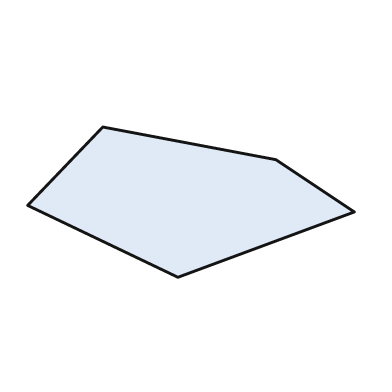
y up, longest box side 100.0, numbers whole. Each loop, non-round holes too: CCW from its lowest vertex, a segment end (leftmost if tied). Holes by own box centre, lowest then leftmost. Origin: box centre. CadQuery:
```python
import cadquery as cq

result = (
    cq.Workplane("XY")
    .moveTo(-4.0, -23.0)
    .lineTo(50.0, -3.0)
    .lineTo(26.0, 13.0)
    .lineTo(-27.0, 23.0)
    .lineTo(-50.0, -1.0)
    .close()
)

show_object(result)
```